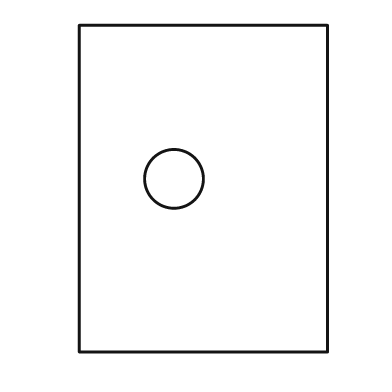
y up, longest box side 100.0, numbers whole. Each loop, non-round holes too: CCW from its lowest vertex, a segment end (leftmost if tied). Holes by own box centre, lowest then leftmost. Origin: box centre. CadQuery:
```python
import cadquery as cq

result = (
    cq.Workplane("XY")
    .moveTo(-38.0, -50.0)
    .lineTo(38.0, -50.0)
    .lineTo(38.0, 50.0)
    .lineTo(-38.0, 50.0)
    .close()
    .moveTo(-9.0, 3.0)
    .circle(9.0)
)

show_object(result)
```